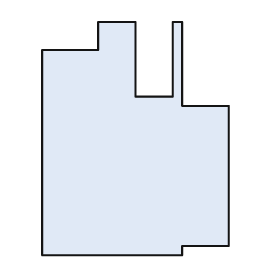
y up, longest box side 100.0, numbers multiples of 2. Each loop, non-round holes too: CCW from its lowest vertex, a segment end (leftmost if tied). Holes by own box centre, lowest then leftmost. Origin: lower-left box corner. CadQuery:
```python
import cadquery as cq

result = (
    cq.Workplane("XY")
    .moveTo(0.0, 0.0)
    .lineTo(60.0, 0.0)
    .lineTo(60.0, 4.0)
    .lineTo(80.0, 4.0)
    .lineTo(80.0, 64.0)
    .lineTo(60.0, 64.0)
    .lineTo(60.0, 100.0)
    .lineTo(56.0, 100.0)
    .lineTo(56.0, 68.0)
    .lineTo(40.0, 68.0)
    .lineTo(40.0, 100.0)
    .lineTo(24.0, 100.0)
    .lineTo(24.0, 88.0)
    .lineTo(0.0, 88.0)
    .close()
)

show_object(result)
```